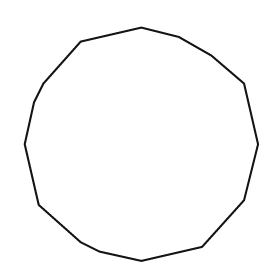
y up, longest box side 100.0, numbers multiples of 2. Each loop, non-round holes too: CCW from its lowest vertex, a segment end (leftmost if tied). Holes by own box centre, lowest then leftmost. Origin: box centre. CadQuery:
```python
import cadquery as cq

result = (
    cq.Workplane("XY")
    .moveTo(0.0, -50.0)
    .lineTo(26.0, -44.0)
    .lineTo(44.0, -24.0)
    .lineTo(50.0, 0.0)
    .lineTo(44.0, 26.0)
    .lineTo(30.0, 38.0)
    .lineTo(16.0, 46.0)
    .lineTo(0.0, 50.0)
    .lineTo(-26.0, 44.0)
    .lineTo(-42.0, 26.0)
    .lineTo(-46.0, 18.0)
    .lineTo(-50.0, 0.0)
    .lineTo(-44.0, -26.0)
    .lineTo(-26.0, -42.0)
    .lineTo(-18.0, -46.0)
    .close()
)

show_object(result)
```